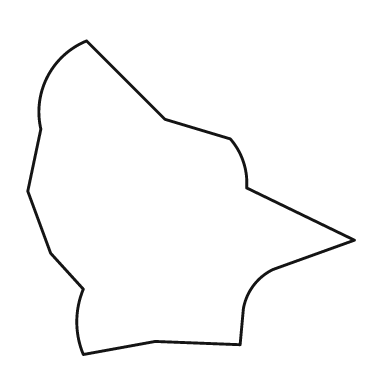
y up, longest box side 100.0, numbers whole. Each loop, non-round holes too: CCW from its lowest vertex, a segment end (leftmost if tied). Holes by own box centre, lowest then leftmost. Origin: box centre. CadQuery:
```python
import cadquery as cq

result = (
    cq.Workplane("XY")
    .moveTo(-33.0, -48.0)
    .lineTo(-11.0, -44.0)
    .lineTo(15.0, -45.0)
    .lineTo(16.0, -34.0)
    .threePointArc((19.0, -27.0), (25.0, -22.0))
    .lineTo(50.0, -13.0)
    .lineTo(17.0, 3.0)
    .threePointArc((16.0, 11.0), (12.0, 18.0))
    .lineTo(-8.0, 24.0)
    .lineTo(-32.0, 48.0)
    .threePointArc((-44.0, 37.0), (-46.0, 21.0))
    .lineTo(-50.0, 2.0)
    .lineTo(-43.0, -17.0)
    .lineTo(-33.0, -28.0)
    .threePointArc((-35.0, -38.0), (-33.0, -48.0))
    .close()
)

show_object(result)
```